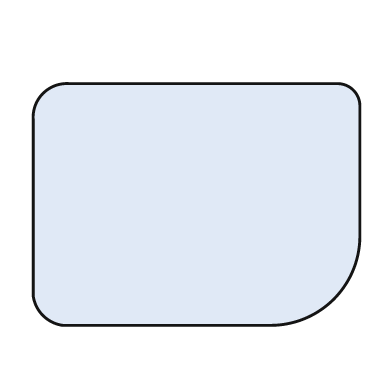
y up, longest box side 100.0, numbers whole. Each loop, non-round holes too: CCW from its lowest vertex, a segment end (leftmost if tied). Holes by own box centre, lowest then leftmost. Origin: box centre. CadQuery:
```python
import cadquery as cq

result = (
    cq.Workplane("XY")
    .moveTo(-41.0, -37.0)
    .lineTo(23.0, -37.0)
    .threePointArc((42.0, -29.0), (50.0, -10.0))
    .lineTo(50.0, 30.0)
    .threePointArc((48.0, 35.0), (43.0, 37.0))
    .lineTo(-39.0, 37.0)
    .threePointArc((-47.0, 34.0), (-50.0, 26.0))
    .lineTo(-50.0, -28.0)
    .threePointArc((-47.0, -34.0), (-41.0, -37.0))
    .close()
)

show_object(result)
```